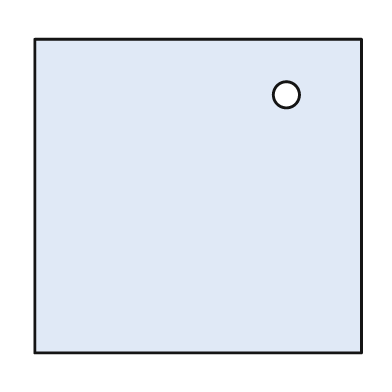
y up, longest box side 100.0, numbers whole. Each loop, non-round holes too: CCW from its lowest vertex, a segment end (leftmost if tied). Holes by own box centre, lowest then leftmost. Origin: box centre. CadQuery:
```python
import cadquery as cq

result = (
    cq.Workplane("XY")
    .moveTo(-50.0, -48.0)
    .lineTo(50.0, -48.0)
    .lineTo(50.0, 48.0)
    .lineTo(-50.0, 48.0)
    .close()
    .moveTo(27.0, 31.0)
    .circle(4.0)
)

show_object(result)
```